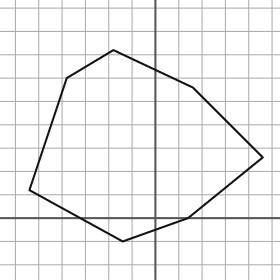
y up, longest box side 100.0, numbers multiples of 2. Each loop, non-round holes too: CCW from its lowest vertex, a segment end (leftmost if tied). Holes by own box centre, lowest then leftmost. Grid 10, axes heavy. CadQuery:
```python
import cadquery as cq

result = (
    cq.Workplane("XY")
    .moveTo(-14.0, -10.0)
    .lineTo(14.0, 0.0)
    .lineTo(46.0, 26.0)
    .lineTo(16.0, 56.0)
    .lineTo(-18.0, 72.0)
    .lineTo(-38.0, 60.0)
    .lineTo(-54.0, 12.0)
    .close()
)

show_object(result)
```